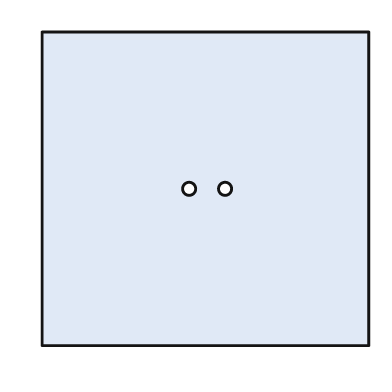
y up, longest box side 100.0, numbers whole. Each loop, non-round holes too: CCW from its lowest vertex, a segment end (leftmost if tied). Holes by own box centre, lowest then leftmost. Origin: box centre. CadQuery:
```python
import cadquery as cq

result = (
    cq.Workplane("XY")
    .moveTo(-50.0, -48.0)
    .lineTo(50.0, -48.0)
    .lineTo(50.0, 48.0)
    .lineTo(-50.0, 48.0)
    .close()
    .moveTo(-5.0, 0.0)
    .circle(2.0)
    .moveTo(6.0, 0.0)
    .circle(2.0)
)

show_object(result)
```